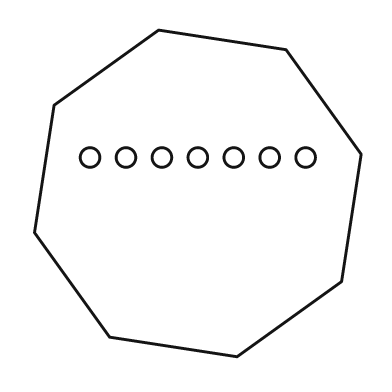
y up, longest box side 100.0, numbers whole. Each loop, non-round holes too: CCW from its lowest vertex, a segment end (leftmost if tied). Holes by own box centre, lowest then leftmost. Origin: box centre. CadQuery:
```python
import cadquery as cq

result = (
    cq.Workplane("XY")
    .moveTo(12.0, -50.0)
    .lineTo(44.0, -27.0)
    .lineTo(50.0, 12.0)
    .lineTo(27.0, 44.0)
    .lineTo(-12.0, 50.0)
    .lineTo(-44.0, 27.0)
    .lineTo(-50.0, -12.0)
    .lineTo(-27.0, -44.0)
    .close()
    .moveTo(-33.0, 11.0)
    .circle(3.0)
    .moveTo(-22.0, 11.0)
    .circle(3.0)
    .moveTo(-11.0, 11.0)
    .circle(3.0)
    .moveTo(0.0, 11.0)
    .circle(3.0)
    .moveTo(11.0, 11.0)
    .circle(3.0)
    .moveTo(22.0, 11.0)
    .circle(3.0)
    .moveTo(33.0, 11.0)
    .circle(3.0)
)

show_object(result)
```